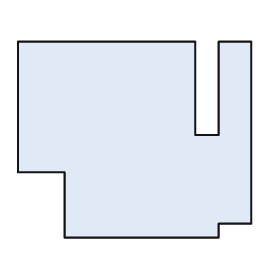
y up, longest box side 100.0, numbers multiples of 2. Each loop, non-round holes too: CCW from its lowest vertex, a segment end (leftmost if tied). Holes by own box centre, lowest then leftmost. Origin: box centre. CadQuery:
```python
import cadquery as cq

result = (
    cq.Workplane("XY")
    .moveTo(-30.0, -42.0)
    .lineTo(36.0, -42.0)
    .lineTo(36.0, -36.0)
    .lineTo(50.0, -36.0)
    .lineTo(50.0, 42.0)
    .lineTo(36.0, 42.0)
    .lineTo(36.0, 2.0)
    .lineTo(26.0, 2.0)
    .lineTo(26.0, 42.0)
    .lineTo(-50.0, 42.0)
    .lineTo(-50.0, -14.0)
    .lineTo(-30.0, -14.0)
    .close()
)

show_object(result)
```